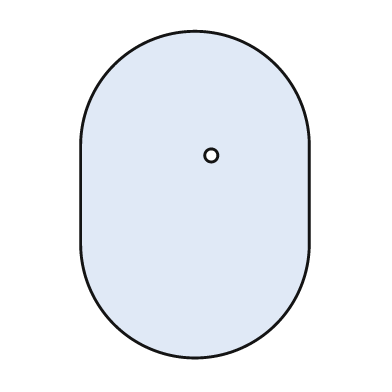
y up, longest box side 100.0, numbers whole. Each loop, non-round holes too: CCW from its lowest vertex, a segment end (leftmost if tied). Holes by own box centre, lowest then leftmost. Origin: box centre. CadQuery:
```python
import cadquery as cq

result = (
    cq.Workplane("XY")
    .moveTo(-35.0, -15.0)
    .threePointArc((0.0, -50.0), (35.0, -15.0))
    .lineTo(35.0, 15.0)
    .threePointArc((0.0, 50.0), (-35.0, 15.0))
    .close()
    .moveTo(5.0, 12.0)
    .circle(2.0)
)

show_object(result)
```